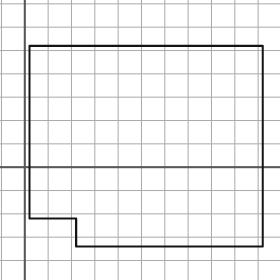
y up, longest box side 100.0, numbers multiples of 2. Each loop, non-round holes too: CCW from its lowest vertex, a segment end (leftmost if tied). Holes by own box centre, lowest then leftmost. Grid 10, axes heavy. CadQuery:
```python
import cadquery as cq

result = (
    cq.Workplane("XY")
    .moveTo(22.0, -34.0)
    .lineTo(102.0, -34.0)
    .lineTo(102.0, 52.0)
    .lineTo(2.0, 52.0)
    .lineTo(2.0, -22.0)
    .lineTo(22.0, -22.0)
    .close()
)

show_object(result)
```